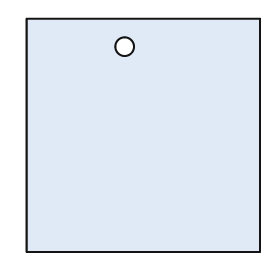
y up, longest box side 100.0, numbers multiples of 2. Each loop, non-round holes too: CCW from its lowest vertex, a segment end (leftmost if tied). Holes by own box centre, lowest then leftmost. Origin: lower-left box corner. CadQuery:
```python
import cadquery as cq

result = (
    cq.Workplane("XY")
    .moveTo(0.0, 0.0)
    .lineTo(100.0, 0.0)
    .lineTo(100.0, 100.0)
    .lineTo(0.0, 100.0)
    .close()
    .moveTo(42.0, 88.0)
    .circle(4.0)
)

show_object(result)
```